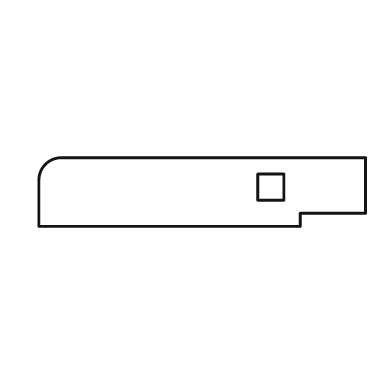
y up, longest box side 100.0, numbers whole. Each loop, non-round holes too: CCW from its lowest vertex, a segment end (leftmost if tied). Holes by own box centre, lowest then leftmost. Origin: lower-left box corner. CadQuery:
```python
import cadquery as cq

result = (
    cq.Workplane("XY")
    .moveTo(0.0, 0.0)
    .lineTo(80.0, 0.0)
    .lineTo(80.0, 4.0)
    .lineTo(100.0, 4.0)
    .lineTo(100.0, 21.0)
    .lineTo(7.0, 21.0)
    .threePointArc((2.0, 19.0), (0.0, 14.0))
    .close()
    .moveTo(67.0, 8.0)
    .lineTo(75.0, 8.0)
    .lineTo(75.0, 16.0)
    .lineTo(67.0, 16.0)
    .close()
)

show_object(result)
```